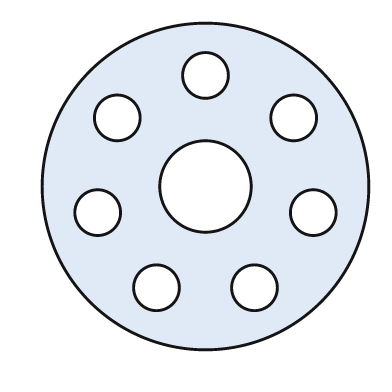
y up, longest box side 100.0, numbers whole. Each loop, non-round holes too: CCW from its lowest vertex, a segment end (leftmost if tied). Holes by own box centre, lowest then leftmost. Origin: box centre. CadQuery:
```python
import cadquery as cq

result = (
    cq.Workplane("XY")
    .moveTo(0.0, 0.0)
    .circle(50.0)
    .moveTo(-15.0, -31.0)
    .circle(7.0)
    .moveTo(15.0, -31.0)
    .circle(7.0)
    .moveTo(-33.0, -8.0)
    .circle(7.0)
    .moveTo(33.0, -8.0)
    .circle(7.0)
    .moveTo(0.0, 0.0)
    .circle(14.0)
    .moveTo(-27.0, 21.0)
    .circle(7.0)
    .moveTo(27.0, 21.0)
    .circle(7.0)
    .moveTo(0.0, 34.0)
    .circle(7.0)
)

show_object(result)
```